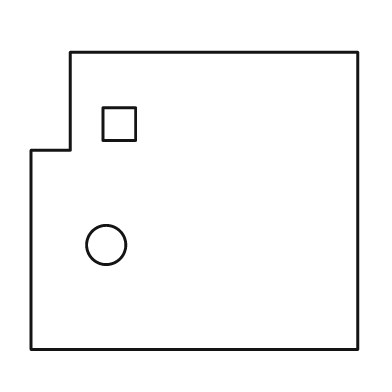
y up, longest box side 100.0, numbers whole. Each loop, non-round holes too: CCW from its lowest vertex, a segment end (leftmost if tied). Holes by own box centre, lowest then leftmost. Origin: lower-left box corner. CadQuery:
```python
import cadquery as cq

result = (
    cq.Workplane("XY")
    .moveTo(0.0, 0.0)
    .lineTo(100.0, 0.0)
    .lineTo(100.0, 91.0)
    .lineTo(12.0, 91.0)
    .lineTo(12.0, 61.0)
    .lineTo(0.0, 61.0)
    .close()
    .moveTo(23.0, 32.0)
    .circle(6.0)
    .moveTo(22.0, 64.0)
    .lineTo(32.0, 64.0)
    .lineTo(32.0, 74.0)
    .lineTo(22.0, 74.0)
    .close()
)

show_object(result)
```